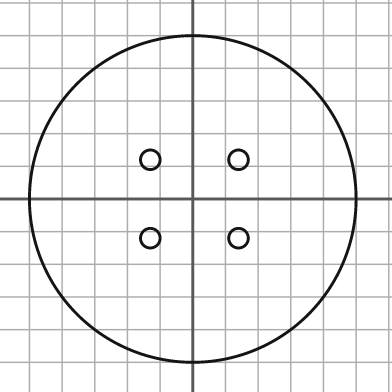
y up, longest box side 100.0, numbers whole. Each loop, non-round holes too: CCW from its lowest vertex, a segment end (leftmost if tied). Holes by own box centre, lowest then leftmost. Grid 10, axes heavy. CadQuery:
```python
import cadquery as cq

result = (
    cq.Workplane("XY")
    .moveTo(0.0, 0.0)
    .circle(50.0)
    .moveTo(-13.0, -12.0)
    .circle(3.0)
    .moveTo(14.0, -12.0)
    .circle(3.0)
    .moveTo(-13.0, 12.0)
    .circle(3.0)
    .moveTo(14.0, 12.0)
    .circle(3.0)
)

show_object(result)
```